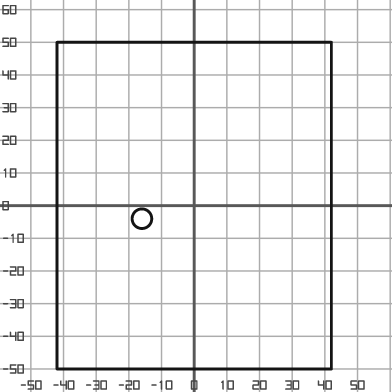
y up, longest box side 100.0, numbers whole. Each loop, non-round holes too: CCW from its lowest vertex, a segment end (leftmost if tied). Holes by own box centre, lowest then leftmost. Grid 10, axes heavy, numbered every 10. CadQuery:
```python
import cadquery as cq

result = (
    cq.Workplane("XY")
    .moveTo(-42.0, -50.0)
    .lineTo(42.0, -50.0)
    .lineTo(42.0, 50.0)
    .lineTo(-42.0, 50.0)
    .close()
    .moveTo(-16.0, -4.0)
    .circle(3.0)
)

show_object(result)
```